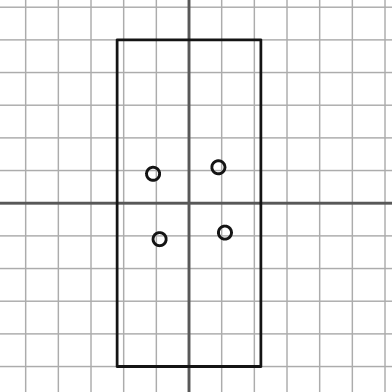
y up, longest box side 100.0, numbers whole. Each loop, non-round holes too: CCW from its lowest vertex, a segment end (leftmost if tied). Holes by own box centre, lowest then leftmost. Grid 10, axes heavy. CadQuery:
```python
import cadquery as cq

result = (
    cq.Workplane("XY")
    .moveTo(-22.0, -50.0)
    .lineTo(22.0, -50.0)
    .lineTo(22.0, 50.0)
    .lineTo(-22.0, 50.0)
    .close()
    .moveTo(-9.0, -11.0)
    .circle(2.0)
    .moveTo(11.0, -9.0)
    .circle(2.0)
    .moveTo(-11.0, 9.0)
    .circle(2.0)
    .moveTo(9.0, 11.0)
    .circle(2.0)
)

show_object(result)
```